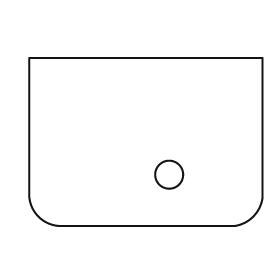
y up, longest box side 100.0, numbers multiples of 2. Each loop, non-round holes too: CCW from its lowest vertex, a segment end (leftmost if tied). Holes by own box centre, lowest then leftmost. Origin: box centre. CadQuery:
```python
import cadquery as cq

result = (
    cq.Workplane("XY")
    .moveTo(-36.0, -36.0)
    .lineTo(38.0, -36.0)
    .threePointArc((46.0, -32.0), (50.0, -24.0))
    .lineTo(50.0, 36.0)
    .lineTo(-50.0, 36.0)
    .lineTo(-50.0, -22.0)
    .threePointArc((-46.0, -32.0), (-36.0, -36.0))
    .close()
    .moveTo(10.0, -14.0)
    .circle(6.0)
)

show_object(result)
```